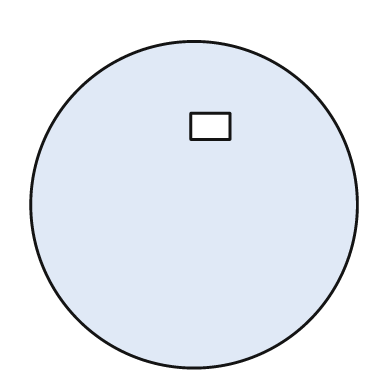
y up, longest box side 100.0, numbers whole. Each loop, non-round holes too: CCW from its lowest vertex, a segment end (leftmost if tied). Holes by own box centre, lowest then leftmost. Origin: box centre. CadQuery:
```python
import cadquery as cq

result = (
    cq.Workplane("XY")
    .moveTo(0.0, 0.0)
    .circle(50.0)
    .moveTo(-1.0, 20.0)
    .lineTo(11.0, 20.0)
    .lineTo(11.0, 28.0)
    .lineTo(-1.0, 28.0)
    .close()
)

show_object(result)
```